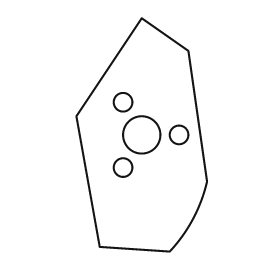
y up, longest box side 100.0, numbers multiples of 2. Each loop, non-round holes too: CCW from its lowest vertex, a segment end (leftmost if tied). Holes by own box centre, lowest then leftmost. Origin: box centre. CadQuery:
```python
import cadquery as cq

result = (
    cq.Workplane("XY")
    .moveTo(12.0, -50.0)
    .threePointArc((22.0, -36.0), (28.0, -20.0))
    .lineTo(20.0, 36.0)
    .lineTo(0.0, 50.0)
    .lineTo(-28.0, 8.0)
    .lineTo(-18.0, -48.0)
    .close()
    .moveTo(-8.0, -14.0)
    .circle(4.0)
    .moveTo(0.0, 0.0)
    .circle(8.0)
    .moveTo(16.0, 0.0)
    .circle(4.0)
    .moveTo(-8.0, 14.0)
    .circle(4.0)
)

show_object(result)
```